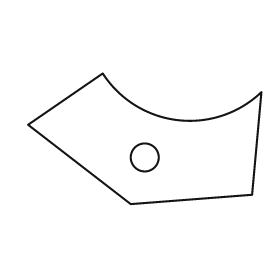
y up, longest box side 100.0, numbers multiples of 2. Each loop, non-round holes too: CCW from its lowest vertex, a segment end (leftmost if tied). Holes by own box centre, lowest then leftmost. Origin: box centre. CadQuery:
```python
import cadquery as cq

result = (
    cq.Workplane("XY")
    .moveTo(-6.0, -28.0)
    .lineTo(46.0, -24.0)
    .lineTo(50.0, 20.0)
    .threePointArc((14.0, 8.0), (-18.0, 28.0))
    .lineTo(-50.0, 6.0)
    .close()
    .moveTo(0.0, -8.0)
    .circle(6.0)
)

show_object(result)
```